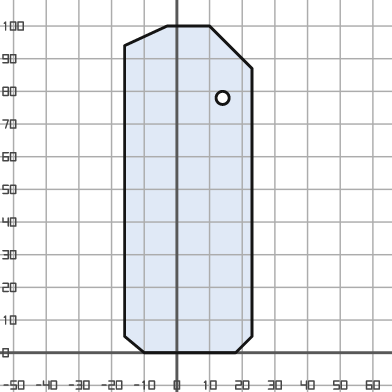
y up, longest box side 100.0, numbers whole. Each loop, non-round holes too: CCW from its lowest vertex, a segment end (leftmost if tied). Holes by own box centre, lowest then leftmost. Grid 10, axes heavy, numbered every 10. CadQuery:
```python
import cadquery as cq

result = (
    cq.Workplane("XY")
    .moveTo(-10.0, 0.0)
    .lineTo(18.0, 0.0)
    .lineTo(23.0, 5.0)
    .lineTo(23.0, 87.0)
    .lineTo(10.0, 100.0)
    .lineTo(-3.0, 100.0)
    .lineTo(-16.0, 94.0)
    .lineTo(-16.0, 5.0)
    .close()
    .moveTo(14.0, 78.0)
    .circle(2.0)
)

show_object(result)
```